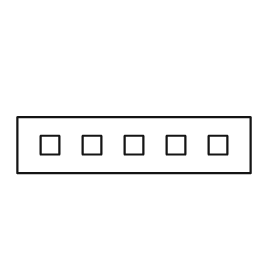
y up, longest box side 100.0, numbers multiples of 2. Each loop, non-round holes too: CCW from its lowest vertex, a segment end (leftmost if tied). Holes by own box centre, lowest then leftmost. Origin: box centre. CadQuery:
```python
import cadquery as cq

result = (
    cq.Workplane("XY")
    .moveTo(-50.0, -12.0)
    .lineTo(50.0, -12.0)
    .lineTo(50.0, 12.0)
    .lineTo(-50.0, 12.0)
    .close()
    .moveTo(-40.0, -4.0)
    .lineTo(-32.0, -4.0)
    .lineTo(-32.0, 4.0)
    .lineTo(-40.0, 4.0)
    .close()
    .moveTo(-22.0, -4.0)
    .lineTo(-14.0, -4.0)
    .lineTo(-14.0, 4.0)
    .lineTo(-22.0, 4.0)
    .close()
    .moveTo(-4.0, -4.0)
    .lineTo(4.0, -4.0)
    .lineTo(4.0, 4.0)
    .lineTo(-4.0, 4.0)
    .close()
    .moveTo(14.0, -4.0)
    .lineTo(22.0, -4.0)
    .lineTo(22.0, 4.0)
    .lineTo(14.0, 4.0)
    .close()
    .moveTo(32.0, -4.0)
    .lineTo(40.0, -4.0)
    .lineTo(40.0, 4.0)
    .lineTo(32.0, 4.0)
    .close()
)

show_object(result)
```